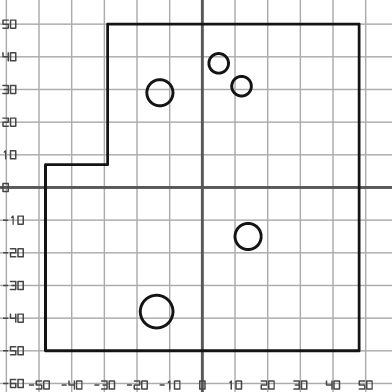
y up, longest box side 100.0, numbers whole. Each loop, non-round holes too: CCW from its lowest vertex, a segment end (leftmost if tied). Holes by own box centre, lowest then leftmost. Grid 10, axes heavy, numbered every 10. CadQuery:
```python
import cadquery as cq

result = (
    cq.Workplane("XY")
    .moveTo(-48.0, -50.0)
    .lineTo(48.0, -50.0)
    .lineTo(48.0, 50.0)
    .lineTo(-29.0, 50.0)
    .lineTo(-29.0, 7.0)
    .lineTo(-48.0, 7.0)
    .close()
    .moveTo(-14.0, -38.0)
    .circle(5.0)
    .moveTo(14.0, -15.0)
    .circle(4.0)
    .moveTo(-13.0, 29.0)
    .circle(4.0)
    .moveTo(12.0, 31.0)
    .circle(3.0)
    .moveTo(5.0, 38.0)
    .circle(3.0)
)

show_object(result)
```